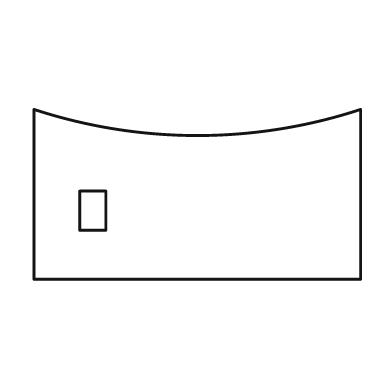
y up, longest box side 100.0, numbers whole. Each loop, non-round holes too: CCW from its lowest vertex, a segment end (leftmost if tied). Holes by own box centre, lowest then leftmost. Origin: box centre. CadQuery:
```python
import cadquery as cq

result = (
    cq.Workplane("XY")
    .moveTo(-50.0, -26.0)
    .lineTo(50.0, -26.0)
    .lineTo(50.0, 26.0)
    .threePointArc((0.0, 18.0), (-50.0, 26.0))
    .close()
    .moveTo(-36.0, -11.0)
    .lineTo(-28.0, -11.0)
    .lineTo(-28.0, 1.0)
    .lineTo(-36.0, 1.0)
    .close()
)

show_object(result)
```